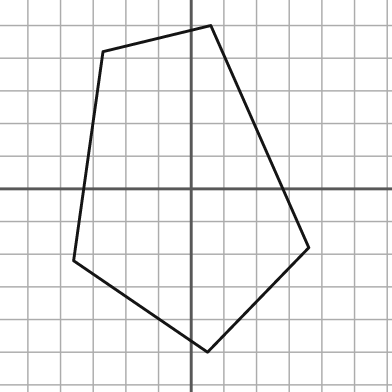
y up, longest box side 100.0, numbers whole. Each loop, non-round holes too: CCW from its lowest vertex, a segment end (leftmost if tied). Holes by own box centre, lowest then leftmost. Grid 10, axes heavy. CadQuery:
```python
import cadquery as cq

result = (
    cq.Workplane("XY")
    .moveTo(5.0, -50.0)
    .lineTo(36.0, -18.0)
    .lineTo(6.0, 50.0)
    .lineTo(-27.0, 42.0)
    .lineTo(-36.0, -22.0)
    .close()
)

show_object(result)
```